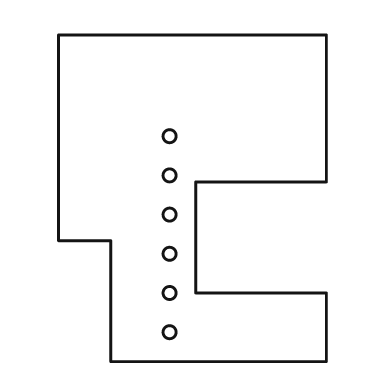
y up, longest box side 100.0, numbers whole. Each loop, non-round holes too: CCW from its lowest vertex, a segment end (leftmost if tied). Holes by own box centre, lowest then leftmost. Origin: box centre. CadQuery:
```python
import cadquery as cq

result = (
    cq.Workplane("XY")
    .moveTo(-25.0, -50.0)
    .lineTo(41.0, -50.0)
    .lineTo(41.0, -29.0)
    .lineTo(1.0, -29.0)
    .lineTo(1.0, 5.0)
    .lineTo(41.0, 5.0)
    .lineTo(41.0, 50.0)
    .lineTo(-41.0, 50.0)
    .lineTo(-41.0, -13.0)
    .lineTo(-25.0, -13.0)
    .close()
    .moveTo(-7.0, -41.0)
    .circle(2.0)
    .moveTo(-7.0, -29.0)
    .circle(2.0)
    .moveTo(-7.0, -17.0)
    .circle(2.0)
    .moveTo(-7.0, -5.0)
    .circle(2.0)
    .moveTo(-7.0, 7.0)
    .circle(2.0)
    .moveTo(-7.0, 19.0)
    .circle(2.0)
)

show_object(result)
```